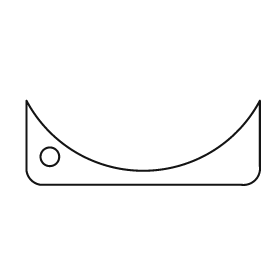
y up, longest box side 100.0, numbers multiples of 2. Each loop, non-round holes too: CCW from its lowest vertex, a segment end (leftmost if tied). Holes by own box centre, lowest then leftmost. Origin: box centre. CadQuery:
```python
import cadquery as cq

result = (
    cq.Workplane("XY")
    .moveTo(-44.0, -18.0)
    .lineTo(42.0, -18.0)
    .threePointArc((48.0, -16.0), (50.0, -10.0))
    .lineTo(50.0, 18.0)
    .threePointArc((0.0, -12.0), (-50.0, 18.0))
    .lineTo(-50.0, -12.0)
    .threePointArc((-48.0, -16.0), (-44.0, -18.0))
    .close()
    .moveTo(-40.0, -6.0)
    .circle(4.0)
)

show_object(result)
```